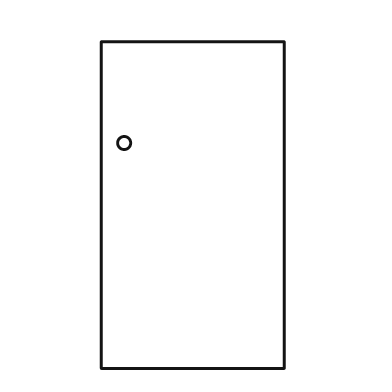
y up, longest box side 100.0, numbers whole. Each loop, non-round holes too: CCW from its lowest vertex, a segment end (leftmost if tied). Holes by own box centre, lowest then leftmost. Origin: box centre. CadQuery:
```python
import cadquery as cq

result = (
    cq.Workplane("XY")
    .moveTo(-28.0, -50.0)
    .lineTo(28.0, -50.0)
    .lineTo(28.0, 50.0)
    .lineTo(-28.0, 50.0)
    .close()
    .moveTo(-21.0, 19.0)
    .circle(2.0)
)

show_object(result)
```